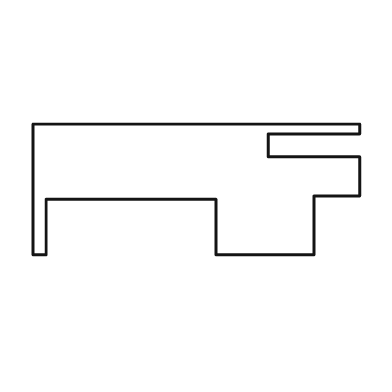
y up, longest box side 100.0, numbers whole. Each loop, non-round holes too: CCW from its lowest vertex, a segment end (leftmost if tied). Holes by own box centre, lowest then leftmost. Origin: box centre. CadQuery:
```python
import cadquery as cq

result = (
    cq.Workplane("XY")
    .moveTo(-50.0, -20.0)
    .lineTo(-46.0, -20.0)
    .lineTo(-46.0, -3.0)
    .lineTo(6.0, -3.0)
    .lineTo(6.0, -20.0)
    .lineTo(36.0, -20.0)
    .lineTo(36.0, -2.0)
    .lineTo(50.0, -2.0)
    .lineTo(50.0, 10.0)
    .lineTo(22.0, 10.0)
    .lineTo(22.0, 17.0)
    .lineTo(50.0, 17.0)
    .lineTo(50.0, 20.0)
    .lineTo(-50.0, 20.0)
    .close()
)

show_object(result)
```